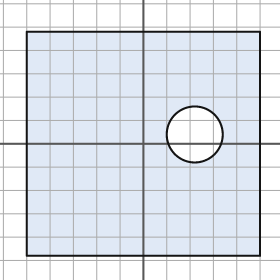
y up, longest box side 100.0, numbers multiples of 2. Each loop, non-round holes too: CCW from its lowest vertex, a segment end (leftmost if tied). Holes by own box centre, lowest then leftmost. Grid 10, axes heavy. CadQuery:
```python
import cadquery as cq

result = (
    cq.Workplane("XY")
    .moveTo(-50.0, -48.0)
    .lineTo(50.0, -48.0)
    .lineTo(50.0, 48.0)
    .lineTo(-50.0, 48.0)
    .close()
    .moveTo(22.0, 4.0)
    .circle(12.0)
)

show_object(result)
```